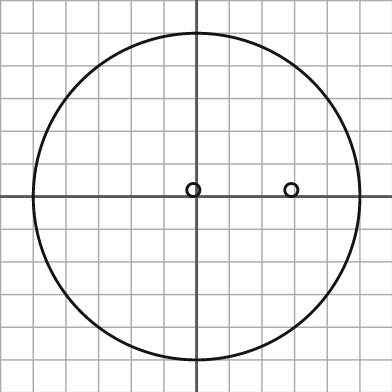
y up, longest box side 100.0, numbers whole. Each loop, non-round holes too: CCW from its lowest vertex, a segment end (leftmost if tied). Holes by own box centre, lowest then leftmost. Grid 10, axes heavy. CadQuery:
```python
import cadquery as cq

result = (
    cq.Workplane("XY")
    .moveTo(0.0, 0.0)
    .circle(50.0)
    .moveTo(-1.0, 2.0)
    .circle(2.0)
    .moveTo(29.0, 2.0)
    .circle(2.0)
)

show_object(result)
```